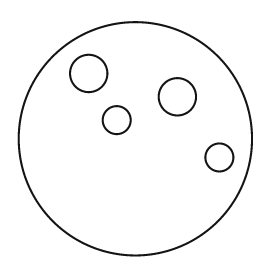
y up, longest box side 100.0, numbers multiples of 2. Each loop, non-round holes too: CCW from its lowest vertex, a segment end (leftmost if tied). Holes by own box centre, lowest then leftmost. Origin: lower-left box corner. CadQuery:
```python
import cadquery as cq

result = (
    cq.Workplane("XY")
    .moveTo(50.0, 50.0)
    .circle(50.0)
    .moveTo(86.0, 42.0)
    .circle(6.0)
    .moveTo(42.0, 58.0)
    .circle(6.0)
    .moveTo(68.0, 68.0)
    .circle(8.0)
    .moveTo(30.0, 78.0)
    .circle(8.0)
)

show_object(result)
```